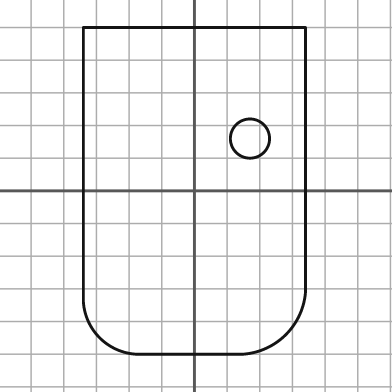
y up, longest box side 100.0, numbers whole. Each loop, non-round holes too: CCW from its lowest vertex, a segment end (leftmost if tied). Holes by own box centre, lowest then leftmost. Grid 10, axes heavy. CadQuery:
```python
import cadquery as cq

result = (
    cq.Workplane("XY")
    .moveTo(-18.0, -50.0)
    .lineTo(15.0, -50.0)
    .threePointArc((28.0, -44.0), (34.0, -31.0))
    .lineTo(34.0, 50.0)
    .lineTo(-34.0, 50.0)
    .lineTo(-34.0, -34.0)
    .threePointArc((-29.0, -45.0), (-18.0, -50.0))
    .close()
    .moveTo(17.0, 16.0)
    .circle(6.0)
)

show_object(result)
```